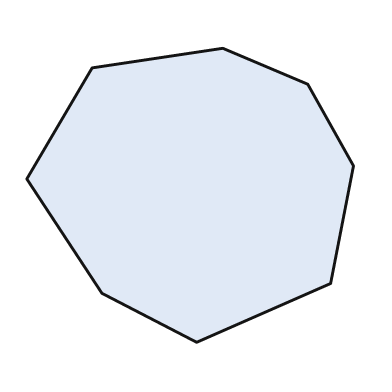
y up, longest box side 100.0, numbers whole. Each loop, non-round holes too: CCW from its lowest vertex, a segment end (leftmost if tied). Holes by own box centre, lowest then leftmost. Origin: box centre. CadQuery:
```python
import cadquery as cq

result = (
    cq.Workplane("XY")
    .moveTo(2.0, -45.0)
    .lineTo(43.0, -27.0)
    .lineTo(50.0, 9.0)
    .lineTo(36.0, 34.0)
    .lineTo(10.0, 45.0)
    .lineTo(-30.0, 39.0)
    .lineTo(-50.0, 5.0)
    .lineTo(-27.0, -30.0)
    .close()
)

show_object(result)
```